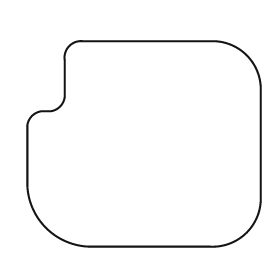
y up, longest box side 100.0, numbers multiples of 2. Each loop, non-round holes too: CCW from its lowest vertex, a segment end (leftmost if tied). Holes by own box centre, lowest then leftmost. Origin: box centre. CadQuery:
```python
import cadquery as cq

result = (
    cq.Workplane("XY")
    .moveTo(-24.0, -44.0)
    .lineTo(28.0, -44.0)
    .threePointArc((44.0, -38.0), (50.0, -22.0))
    .lineTo(50.0, 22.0)
    .threePointArc((44.0, 38.0), (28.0, 44.0))
    .lineTo(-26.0, 44.0)
    .threePointArc((-32.0, 42.0), (-34.0, 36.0))
    .lineTo(-34.0, 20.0)
    .threePointArc((-36.0, 16.0), (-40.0, 14.0))
    .lineTo(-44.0, 14.0)
    .threePointArc((-48.0, 12.0), (-50.0, 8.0))
    .lineTo(-50.0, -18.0)
    .threePointArc((-42.0, -36.0), (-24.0, -44.0))
    .close()
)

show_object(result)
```